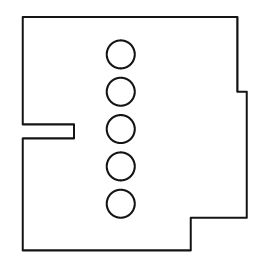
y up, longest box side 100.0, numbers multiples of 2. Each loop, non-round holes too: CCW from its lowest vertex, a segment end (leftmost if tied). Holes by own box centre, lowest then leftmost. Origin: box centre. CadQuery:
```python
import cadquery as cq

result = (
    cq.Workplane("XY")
    .moveTo(-48.0, -50.0)
    .lineTo(24.0, -50.0)
    .lineTo(24.0, -36.0)
    .lineTo(48.0, -36.0)
    .lineTo(48.0, 18.0)
    .lineTo(44.0, 18.0)
    .lineTo(44.0, 50.0)
    .lineTo(-48.0, 50.0)
    .lineTo(-48.0, 4.0)
    .lineTo(-26.0, 4.0)
    .lineTo(-26.0, -2.0)
    .lineTo(-48.0, -2.0)
    .close()
    .moveTo(-6.0, -30.0)
    .circle(6.0)
    .moveTo(-6.0, -14.0)
    .circle(6.0)
    .moveTo(-6.0, 2.0)
    .circle(6.0)
    .moveTo(-6.0, 18.0)
    .circle(6.0)
    .moveTo(-6.0, 34.0)
    .circle(6.0)
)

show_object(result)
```